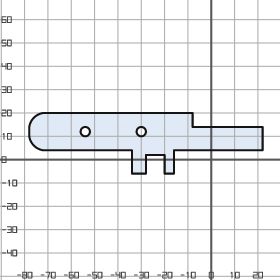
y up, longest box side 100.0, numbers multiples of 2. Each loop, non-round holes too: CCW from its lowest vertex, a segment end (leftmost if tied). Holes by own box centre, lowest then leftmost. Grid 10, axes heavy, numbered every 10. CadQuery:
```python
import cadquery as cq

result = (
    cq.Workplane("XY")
    .moveTo(-34.0, -6.0)
    .lineTo(-28.0, -6.0)
    .lineTo(-28.0, 2.0)
    .lineTo(-20.0, 2.0)
    .lineTo(-20.0, -6.0)
    .lineTo(-16.0, -6.0)
    .lineTo(-16.0, 4.0)
    .lineTo(22.0, 4.0)
    .lineTo(22.0, 14.0)
    .lineTo(-8.0, 14.0)
    .lineTo(-8.0, 20.0)
    .lineTo(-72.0, 20.0)
    .threePointArc((-76.0, 18.0), (-78.0, 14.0))
    .lineTo(-78.0, 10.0)
    .threePointArc((-76.0, 6.0), (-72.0, 4.0))
    .lineTo(-34.0, 4.0)
    .close()
    .moveTo(-54.0, 12.0)
    .circle(2.0)
    .moveTo(-30.0, 12.0)
    .circle(2.0)
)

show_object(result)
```